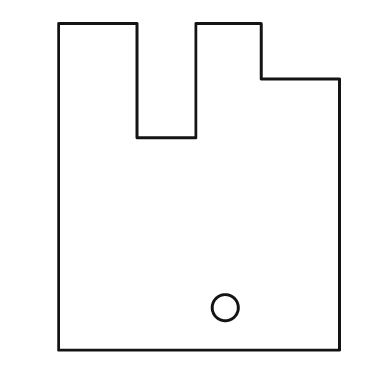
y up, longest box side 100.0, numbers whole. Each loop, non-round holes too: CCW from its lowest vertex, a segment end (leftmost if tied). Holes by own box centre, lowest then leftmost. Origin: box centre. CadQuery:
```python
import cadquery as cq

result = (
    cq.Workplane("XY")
    .moveTo(-43.0, -50.0)
    .lineTo(43.0, -50.0)
    .lineTo(43.0, 33.0)
    .lineTo(19.0, 33.0)
    .lineTo(19.0, 50.0)
    .lineTo(-1.0, 50.0)
    .lineTo(-1.0, 15.0)
    .lineTo(-19.0, 15.0)
    .lineTo(-19.0, 50.0)
    .lineTo(-43.0, 50.0)
    .close()
    .moveTo(8.0, -37.0)
    .circle(4.0)
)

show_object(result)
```